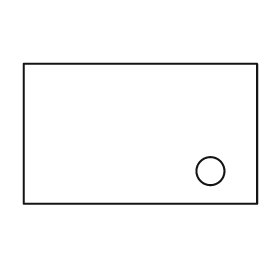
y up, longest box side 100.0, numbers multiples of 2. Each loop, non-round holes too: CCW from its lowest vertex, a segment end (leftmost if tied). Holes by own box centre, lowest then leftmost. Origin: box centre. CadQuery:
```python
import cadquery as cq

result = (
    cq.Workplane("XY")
    .moveTo(-50.0, -30.0)
    .lineTo(50.0, -30.0)
    .lineTo(50.0, 30.0)
    .lineTo(-50.0, 30.0)
    .close()
    .moveTo(30.0, -16.0)
    .circle(6.0)
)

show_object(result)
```